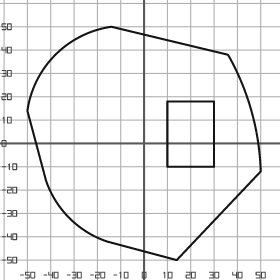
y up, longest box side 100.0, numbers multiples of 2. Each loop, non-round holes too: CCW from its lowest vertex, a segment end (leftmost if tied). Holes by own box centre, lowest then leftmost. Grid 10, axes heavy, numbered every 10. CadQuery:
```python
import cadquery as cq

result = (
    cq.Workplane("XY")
    .moveTo(14.0, -50.0)
    .lineTo(50.0, -12.0)
    .threePointArc((46.0, 14.0), (36.0, 38.0))
    .lineTo(-14.0, 50.0)
    .threePointArc((-38.0, 38.0), (-50.0, 14.0))
    .lineTo(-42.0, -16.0)
    .threePointArc((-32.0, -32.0), (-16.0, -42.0))
    .close()
    .moveTo(10.0, -10.0)
    .lineTo(30.0, -10.0)
    .lineTo(30.0, 18.0)
    .lineTo(10.0, 18.0)
    .close()
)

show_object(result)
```